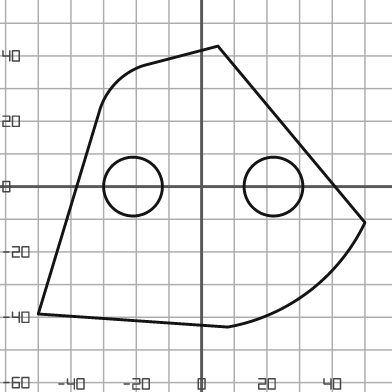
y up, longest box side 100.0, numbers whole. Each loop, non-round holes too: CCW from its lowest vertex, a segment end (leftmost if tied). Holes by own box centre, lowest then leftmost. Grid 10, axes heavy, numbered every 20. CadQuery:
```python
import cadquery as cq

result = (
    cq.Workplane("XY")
    .moveTo(8.0, -43.0)
    .threePointArc((33.0, -32.0), (50.0, -11.0))
    .lineTo(5.0, 43.0)
    .lineTo(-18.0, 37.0)
    .threePointArc((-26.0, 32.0), (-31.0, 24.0))
    .lineTo(-50.0, -39.0)
    .close()
    .moveTo(-21.0, 0.0)
    .circle(9.0)
    .moveTo(22.0, 0.0)
    .circle(9.0)
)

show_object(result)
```